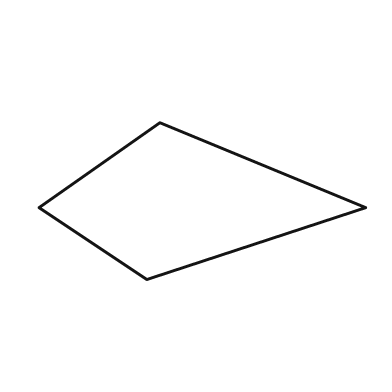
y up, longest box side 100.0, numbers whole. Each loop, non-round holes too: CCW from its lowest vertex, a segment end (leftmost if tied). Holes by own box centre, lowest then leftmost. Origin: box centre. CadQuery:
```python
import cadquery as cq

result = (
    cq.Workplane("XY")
    .moveTo(-17.0, -24.0)
    .lineTo(50.0, -2.0)
    .lineTo(-13.0, 24.0)
    .lineTo(-50.0, -2.0)
    .close()
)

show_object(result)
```